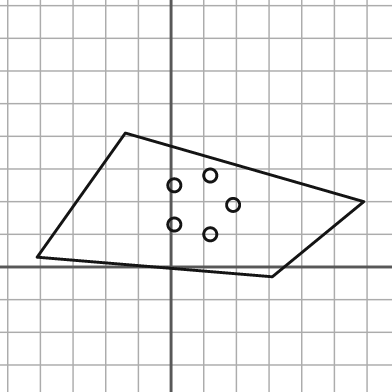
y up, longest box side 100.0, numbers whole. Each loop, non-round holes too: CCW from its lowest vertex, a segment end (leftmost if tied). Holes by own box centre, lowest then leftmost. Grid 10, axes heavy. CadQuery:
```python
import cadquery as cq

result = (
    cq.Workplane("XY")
    .moveTo(31.0, -3.0)
    .lineTo(59.0, 20.0)
    .lineTo(-14.0, 41.0)
    .lineTo(-41.0, 3.0)
    .close()
    .moveTo(12.0, 10.0)
    .circle(2.0)
    .moveTo(1.0, 13.0)
    .circle(2.0)
    .moveTo(19.0, 19.0)
    .circle(2.0)
    .moveTo(1.0, 25.0)
    .circle(2.0)
    .moveTo(12.0, 28.0)
    .circle(2.0)
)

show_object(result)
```